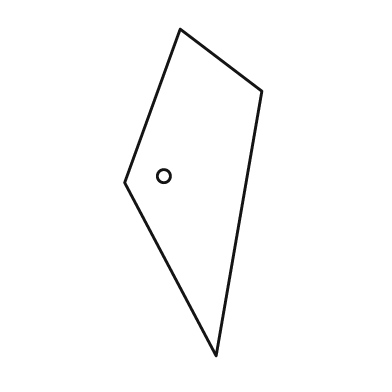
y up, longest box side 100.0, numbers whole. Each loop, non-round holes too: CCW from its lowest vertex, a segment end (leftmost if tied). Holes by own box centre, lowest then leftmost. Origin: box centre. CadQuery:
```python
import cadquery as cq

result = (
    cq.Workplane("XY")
    .moveTo(7.0, -50.0)
    .lineTo(21.0, 31.0)
    .lineTo(-4.0, 50.0)
    .lineTo(-21.0, 3.0)
    .close()
    .moveTo(-9.0, 5.0)
    .circle(2.0)
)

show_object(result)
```